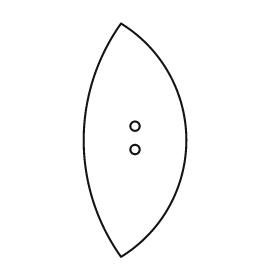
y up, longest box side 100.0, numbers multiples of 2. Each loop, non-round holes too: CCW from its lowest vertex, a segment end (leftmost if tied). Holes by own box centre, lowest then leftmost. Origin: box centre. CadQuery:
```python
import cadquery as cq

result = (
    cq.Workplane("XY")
    .moveTo(-6.0, -50.0)
    .threePointArc((22.0, 0.0), (-6.0, 50.0))
    .threePointArc((-22.0, 0.0), (-6.0, -50.0))
    .close()
    .moveTo(0.0, -4.0)
    .circle(2.0)
    .moveTo(0.0, 6.0)
    .circle(2.0)
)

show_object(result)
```